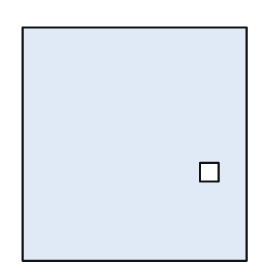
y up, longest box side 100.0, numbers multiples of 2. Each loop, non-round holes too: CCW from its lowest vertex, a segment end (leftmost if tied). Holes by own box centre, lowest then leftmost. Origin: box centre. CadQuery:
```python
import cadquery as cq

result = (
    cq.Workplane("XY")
    .moveTo(-48.0, -50.0)
    .lineTo(48.0, -50.0)
    .lineTo(48.0, 50.0)
    .lineTo(-48.0, 50.0)
    .close()
    .moveTo(28.0, -16.0)
    .lineTo(36.0, -16.0)
    .lineTo(36.0, -8.0)
    .lineTo(28.0, -8.0)
    .close()
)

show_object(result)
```